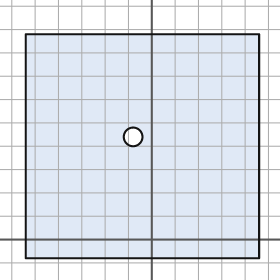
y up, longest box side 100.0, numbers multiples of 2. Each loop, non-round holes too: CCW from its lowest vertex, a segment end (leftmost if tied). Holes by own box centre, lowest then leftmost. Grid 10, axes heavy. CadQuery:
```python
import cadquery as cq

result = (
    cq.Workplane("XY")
    .moveTo(-54.0, -8.0)
    .lineTo(46.0, -8.0)
    .lineTo(46.0, 88.0)
    .lineTo(-54.0, 88.0)
    .close()
    .moveTo(-8.0, 44.0)
    .circle(4.0)
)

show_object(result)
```